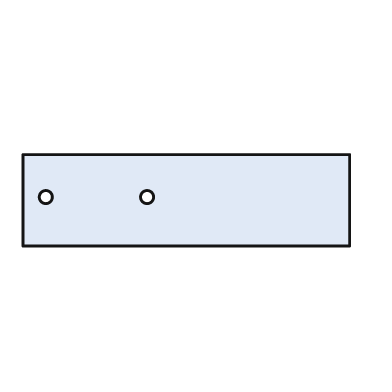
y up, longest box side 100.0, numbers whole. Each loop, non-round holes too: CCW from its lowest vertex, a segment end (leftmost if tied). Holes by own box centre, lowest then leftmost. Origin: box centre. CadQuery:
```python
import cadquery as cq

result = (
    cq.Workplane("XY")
    .moveTo(-50.0, -14.0)
    .lineTo(50.0, -14.0)
    .lineTo(50.0, 14.0)
    .lineTo(-50.0, 14.0)
    .close()
    .moveTo(-43.0, 1.0)
    .circle(2.0)
    .moveTo(-12.0, 1.0)
    .circle(2.0)
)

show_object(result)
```